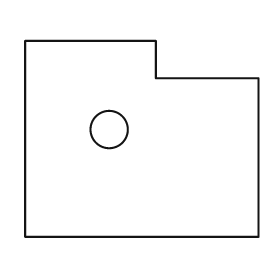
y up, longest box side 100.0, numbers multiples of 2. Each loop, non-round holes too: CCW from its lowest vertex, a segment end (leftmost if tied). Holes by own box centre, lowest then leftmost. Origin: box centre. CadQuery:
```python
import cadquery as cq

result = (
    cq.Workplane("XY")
    .moveTo(-50.0, -42.0)
    .lineTo(50.0, -42.0)
    .lineTo(50.0, 26.0)
    .lineTo(6.0, 26.0)
    .lineTo(6.0, 42.0)
    .lineTo(-50.0, 42.0)
    .close()
    .moveTo(-14.0, 4.0)
    .circle(8.0)
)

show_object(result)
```